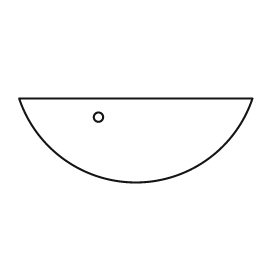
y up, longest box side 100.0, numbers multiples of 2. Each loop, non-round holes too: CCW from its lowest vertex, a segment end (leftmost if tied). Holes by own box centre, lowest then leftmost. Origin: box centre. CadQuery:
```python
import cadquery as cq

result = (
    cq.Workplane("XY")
    .moveTo(-50.0, 18.0)
    .threePointArc((0.0, -18.0), (50.0, 18.0))
    .close()
    .moveTo(-16.0, 10.0)
    .circle(2.0)
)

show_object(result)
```